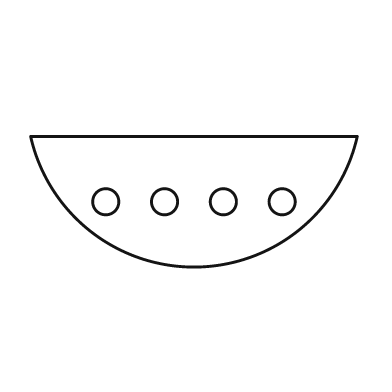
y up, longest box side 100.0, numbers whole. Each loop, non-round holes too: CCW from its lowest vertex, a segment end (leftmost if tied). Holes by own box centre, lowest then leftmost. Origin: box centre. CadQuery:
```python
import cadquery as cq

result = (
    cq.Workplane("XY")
    .moveTo(-50.0, 20.0)
    .threePointArc((0.0, -20.0), (50.0, 20.0))
    .close()
    .moveTo(-27.0, 0.0)
    .circle(4.0)
    .moveTo(-9.0, 0.0)
    .circle(4.0)
    .moveTo(9.0, 0.0)
    .circle(4.0)
    .moveTo(27.0, 0.0)
    .circle(4.0)
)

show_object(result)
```